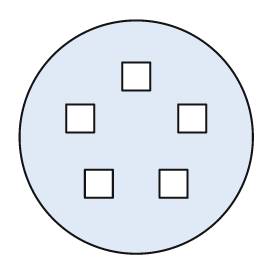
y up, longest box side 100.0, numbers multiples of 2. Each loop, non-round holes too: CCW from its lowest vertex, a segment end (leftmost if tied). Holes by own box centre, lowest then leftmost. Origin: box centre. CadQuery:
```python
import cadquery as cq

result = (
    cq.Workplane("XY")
    .moveTo(0.0, 0.0)
    .circle(50.0)
    .moveTo(-22.0, -26.0)
    .lineTo(-10.0, -26.0)
    .lineTo(-10.0, -14.0)
    .lineTo(-22.0, -14.0)
    .close()
    .moveTo(10.0, -26.0)
    .lineTo(22.0, -26.0)
    .lineTo(22.0, -14.0)
    .lineTo(10.0, -14.0)
    .close()
    .moveTo(-30.0, 2.0)
    .lineTo(-18.0, 2.0)
    .lineTo(-18.0, 14.0)
    .lineTo(-30.0, 14.0)
    .close()
    .moveTo(18.0, 2.0)
    .lineTo(30.0, 2.0)
    .lineTo(30.0, 14.0)
    .lineTo(18.0, 14.0)
    .close()
    .moveTo(-6.0, 20.0)
    .lineTo(6.0, 20.0)
    .lineTo(6.0, 32.0)
    .lineTo(-6.0, 32.0)
    .close()
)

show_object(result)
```